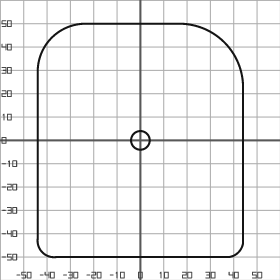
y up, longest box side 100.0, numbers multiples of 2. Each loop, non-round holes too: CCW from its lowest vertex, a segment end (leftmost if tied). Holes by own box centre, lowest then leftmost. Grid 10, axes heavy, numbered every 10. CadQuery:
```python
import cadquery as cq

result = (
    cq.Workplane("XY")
    .moveTo(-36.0, -50.0)
    .lineTo(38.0, -50.0)
    .threePointArc((42.0, -48.0), (44.0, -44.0))
    .lineTo(44.0, 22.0)
    .threePointArc((36.0, 42.0), (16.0, 50.0))
    .lineTo(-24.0, 50.0)
    .threePointArc((-38.0, 44.0), (-44.0, 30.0))
    .lineTo(-44.0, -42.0)
    .threePointArc((-42.0, -48.0), (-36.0, -50.0))
    .close()
    .moveTo(0.0, 0.0)
    .circle(4.0)
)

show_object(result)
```